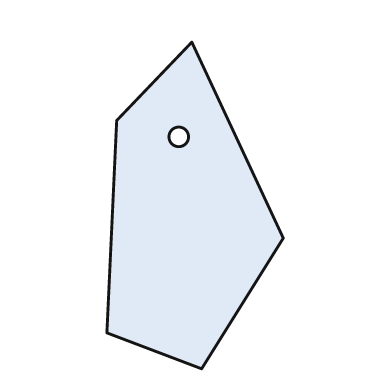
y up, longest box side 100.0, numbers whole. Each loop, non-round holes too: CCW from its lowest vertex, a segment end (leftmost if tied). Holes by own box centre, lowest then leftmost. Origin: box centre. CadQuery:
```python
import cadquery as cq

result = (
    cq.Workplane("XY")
    .moveTo(2.0, -50.0)
    .lineTo(27.0, -10.0)
    .lineTo(-1.0, 50.0)
    .lineTo(-24.0, 26.0)
    .lineTo(-27.0, -39.0)
    .close()
    .moveTo(-5.0, 21.0)
    .circle(3.0)
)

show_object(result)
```